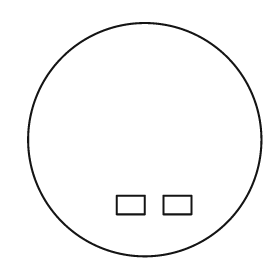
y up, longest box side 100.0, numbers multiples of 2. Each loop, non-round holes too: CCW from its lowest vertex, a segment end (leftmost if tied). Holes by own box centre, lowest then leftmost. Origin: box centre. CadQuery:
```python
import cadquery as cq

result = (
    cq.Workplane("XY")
    .moveTo(0.0, 0.0)
    .circle(50.0)
    .moveTo(-12.0, -32.0)
    .lineTo(0.0, -32.0)
    .lineTo(0.0, -24.0)
    .lineTo(-12.0, -24.0)
    .close()
    .moveTo(8.0, -32.0)
    .lineTo(20.0, -32.0)
    .lineTo(20.0, -24.0)
    .lineTo(8.0, -24.0)
    .close()
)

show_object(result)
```